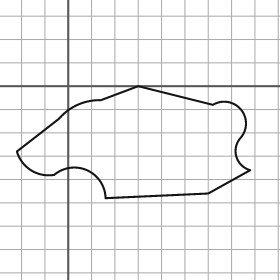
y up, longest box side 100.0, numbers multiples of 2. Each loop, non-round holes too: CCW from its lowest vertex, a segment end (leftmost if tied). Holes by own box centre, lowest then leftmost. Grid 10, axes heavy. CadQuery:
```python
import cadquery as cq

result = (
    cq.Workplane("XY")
    .moveTo(16.0, -48.0)
    .lineTo(60.0, -46.0)
    .lineTo(78.0, -36.0)
    .threePointArc((72.0, -30.0), (74.0, -22.0))
    .threePointArc((74.0, -10.0), (62.0, -8.0))
    .lineTo(30.0, 0.0)
    .lineTo(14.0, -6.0)
    .threePointArc((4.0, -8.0), (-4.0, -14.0))
    .lineTo(-22.0, -28.0)
    .threePointArc((-16.0, -36.0), (-6.0, -38.0))
    .threePointArc((8.0, -36.0), (16.0, -48.0))
    .close()
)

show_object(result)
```